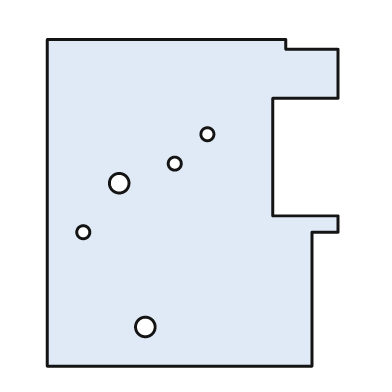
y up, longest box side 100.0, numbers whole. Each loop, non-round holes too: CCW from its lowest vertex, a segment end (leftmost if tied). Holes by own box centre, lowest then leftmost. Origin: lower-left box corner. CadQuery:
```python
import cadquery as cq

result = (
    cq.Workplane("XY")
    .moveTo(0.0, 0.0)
    .lineTo(81.0, 0.0)
    .lineTo(81.0, 41.0)
    .lineTo(89.0, 41.0)
    .lineTo(89.0, 46.0)
    .lineTo(69.0, 46.0)
    .lineTo(69.0, 82.0)
    .lineTo(89.0, 82.0)
    .lineTo(89.0, 97.0)
    .lineTo(73.0, 97.0)
    .lineTo(73.0, 100.0)
    .lineTo(0.0, 100.0)
    .close()
    .moveTo(30.0, 12.0)
    .circle(3.0)
    .moveTo(11.0, 41.0)
    .circle(2.0)
    .moveTo(22.0, 56.0)
    .circle(3.0)
    .moveTo(39.0, 62.0)
    .circle(2.0)
    .moveTo(49.0, 71.0)
    .circle(2.0)
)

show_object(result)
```